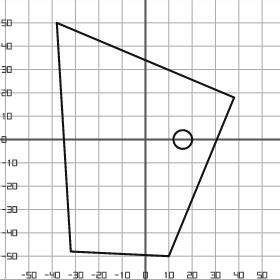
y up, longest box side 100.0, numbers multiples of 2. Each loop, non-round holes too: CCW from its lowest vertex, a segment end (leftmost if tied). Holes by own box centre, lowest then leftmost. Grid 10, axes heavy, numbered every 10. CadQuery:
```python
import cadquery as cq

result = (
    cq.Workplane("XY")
    .moveTo(10.0, -50.0)
    .lineTo(38.0, 18.0)
    .lineTo(-38.0, 50.0)
    .lineTo(-32.0, -48.0)
    .close()
    .moveTo(16.0, 0.0)
    .circle(4.0)
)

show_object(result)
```